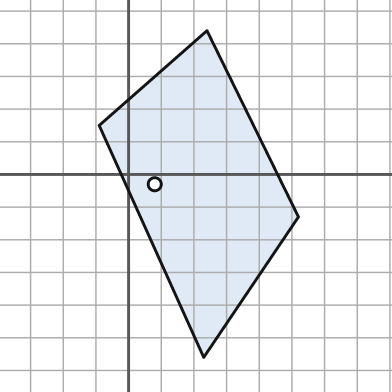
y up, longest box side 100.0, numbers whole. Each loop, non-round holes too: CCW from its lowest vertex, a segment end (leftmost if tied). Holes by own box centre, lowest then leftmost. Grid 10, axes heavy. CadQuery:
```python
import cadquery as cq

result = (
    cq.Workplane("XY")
    .moveTo(23.0, -56.0)
    .lineTo(52.0, -13.0)
    .lineTo(24.0, 44.0)
    .lineTo(-9.0, 15.0)
    .close()
    .moveTo(8.0, -3.0)
    .circle(2.0)
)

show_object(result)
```